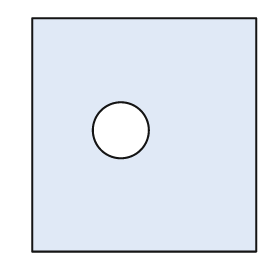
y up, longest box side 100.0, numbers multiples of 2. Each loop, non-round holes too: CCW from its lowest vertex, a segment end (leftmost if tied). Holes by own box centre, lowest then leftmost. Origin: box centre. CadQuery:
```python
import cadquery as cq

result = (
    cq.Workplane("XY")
    .moveTo(-48.0, -50.0)
    .lineTo(48.0, -50.0)
    .lineTo(48.0, 50.0)
    .lineTo(-48.0, 50.0)
    .close()
    .moveTo(-10.0, 2.0)
    .circle(12.0)
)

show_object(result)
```